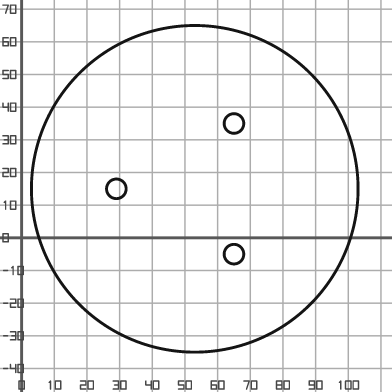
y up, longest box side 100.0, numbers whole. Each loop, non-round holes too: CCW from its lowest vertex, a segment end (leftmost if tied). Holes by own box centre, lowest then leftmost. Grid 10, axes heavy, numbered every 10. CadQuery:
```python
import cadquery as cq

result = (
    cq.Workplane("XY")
    .moveTo(53.0, 15.0)
    .circle(50.0)
    .moveTo(65.0, -5.0)
    .circle(3.0)
    .moveTo(29.0, 15.0)
    .circle(3.0)
    .moveTo(65.0, 35.0)
    .circle(3.0)
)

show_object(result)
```